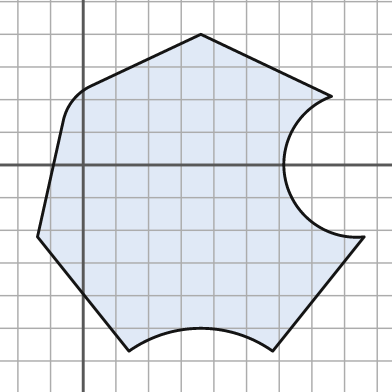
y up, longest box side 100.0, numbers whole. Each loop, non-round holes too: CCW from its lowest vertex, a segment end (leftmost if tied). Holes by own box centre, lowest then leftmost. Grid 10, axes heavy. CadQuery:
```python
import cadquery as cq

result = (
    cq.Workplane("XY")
    .moveTo(14.0, -57.0)
    .threePointArc((36.0, -50.0), (58.0, -57.0))
    .lineTo(86.0, -22.0)
    .threePointArc((62.0, -5.0), (76.0, 21.0))
    .lineTo(36.0, 40.0)
    .lineTo(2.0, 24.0)
    .threePointArc((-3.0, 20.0), (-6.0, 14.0))
    .lineTo(-14.0, -22.0)
    .close()
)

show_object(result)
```